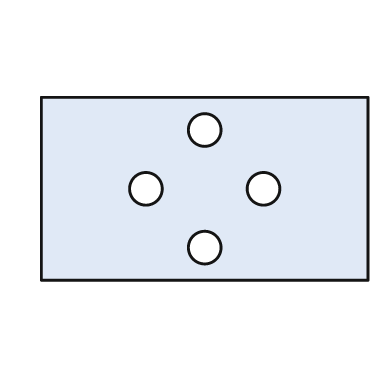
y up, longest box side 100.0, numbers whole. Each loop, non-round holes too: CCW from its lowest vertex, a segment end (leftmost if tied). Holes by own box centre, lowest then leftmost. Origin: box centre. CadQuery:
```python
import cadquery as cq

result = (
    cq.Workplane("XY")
    .moveTo(-50.0, -28.0)
    .lineTo(50.0, -28.0)
    .lineTo(50.0, 28.0)
    .lineTo(-50.0, 28.0)
    .close()
    .moveTo(0.0, -18.0)
    .circle(5.0)
    .moveTo(-18.0, 0.0)
    .circle(5.0)
    .moveTo(18.0, 0.0)
    .circle(5.0)
    .moveTo(0.0, 18.0)
    .circle(5.0)
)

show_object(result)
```